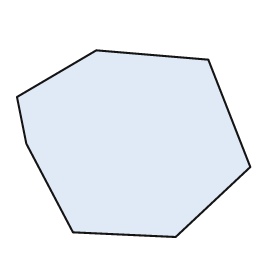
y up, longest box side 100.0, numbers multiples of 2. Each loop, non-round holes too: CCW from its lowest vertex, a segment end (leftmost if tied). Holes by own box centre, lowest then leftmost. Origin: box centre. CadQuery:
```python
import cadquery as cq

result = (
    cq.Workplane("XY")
    .moveTo(18.0, -40.0)
    .lineTo(50.0, -10.0)
    .lineTo(32.0, 36.0)
    .lineTo(-16.0, 40.0)
    .lineTo(-50.0, 20.0)
    .lineTo(-46.0, 0.0)
    .lineTo(-26.0, -38.0)
    .close()
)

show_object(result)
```